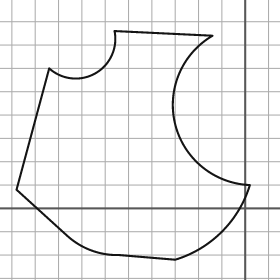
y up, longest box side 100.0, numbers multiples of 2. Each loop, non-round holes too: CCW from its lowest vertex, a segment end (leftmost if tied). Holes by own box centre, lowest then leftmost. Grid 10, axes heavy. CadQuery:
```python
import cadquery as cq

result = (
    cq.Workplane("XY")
    .moveTo(-30.0, -22.0)
    .threePointArc((-10.0, -10.0), (2.0, 10.0))
    .threePointArc((-30.0, 36.0), (-14.0, 74.0))
    .lineTo(-56.0, 76.0)
    .threePointArc((-64.0, 58.0), (-84.0, 60.0))
    .lineTo(-98.0, 8.0)
    .lineTo(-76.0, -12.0)
    .threePointArc((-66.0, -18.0), (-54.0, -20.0))
    .close()
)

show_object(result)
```